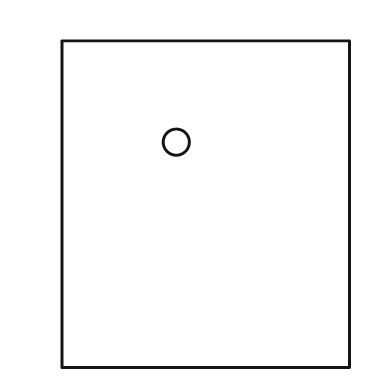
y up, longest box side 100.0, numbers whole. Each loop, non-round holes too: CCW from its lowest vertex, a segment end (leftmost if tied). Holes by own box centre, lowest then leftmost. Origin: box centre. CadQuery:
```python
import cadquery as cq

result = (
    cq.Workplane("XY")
    .moveTo(-44.0, -50.0)
    .lineTo(44.0, -50.0)
    .lineTo(44.0, 50.0)
    .lineTo(-44.0, 50.0)
    .close()
    .moveTo(-9.0, 19.0)
    .circle(4.0)
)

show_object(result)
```